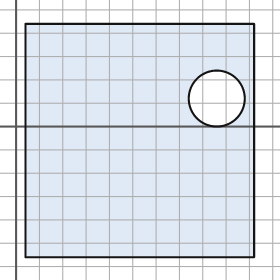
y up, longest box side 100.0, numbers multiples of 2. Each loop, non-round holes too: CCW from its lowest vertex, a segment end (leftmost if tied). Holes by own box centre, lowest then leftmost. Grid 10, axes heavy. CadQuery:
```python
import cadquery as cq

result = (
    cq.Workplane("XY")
    .moveTo(4.0, -56.0)
    .lineTo(102.0, -56.0)
    .lineTo(102.0, 44.0)
    .lineTo(4.0, 44.0)
    .close()
    .moveTo(86.0, 12.0)
    .circle(12.0)
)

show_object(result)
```